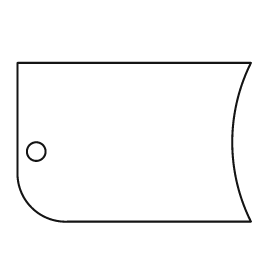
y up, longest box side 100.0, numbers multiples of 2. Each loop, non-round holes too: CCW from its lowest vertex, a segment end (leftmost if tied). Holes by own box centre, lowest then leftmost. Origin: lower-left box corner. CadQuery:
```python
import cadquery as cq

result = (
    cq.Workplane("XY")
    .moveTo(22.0, 0.0)
    .lineTo(100.0, 0.0)
    .threePointArc((92.0, 34.0), (100.0, 68.0))
    .lineTo(0.0, 68.0)
    .lineTo(0.0, 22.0)
    .threePointArc((6.0, 6.0), (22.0, 0.0))
    .close()
    .moveTo(8.0, 30.0)
    .circle(4.0)
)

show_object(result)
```